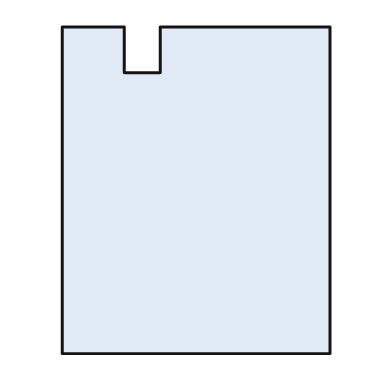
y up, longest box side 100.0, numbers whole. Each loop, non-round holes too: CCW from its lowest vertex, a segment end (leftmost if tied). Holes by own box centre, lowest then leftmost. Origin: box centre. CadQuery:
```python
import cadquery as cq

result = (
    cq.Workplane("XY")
    .moveTo(-41.0, -50.0)
    .lineTo(41.0, -50.0)
    .lineTo(41.0, 50.0)
    .lineTo(-11.0, 50.0)
    .lineTo(-11.0, 36.0)
    .lineTo(-22.0, 36.0)
    .lineTo(-22.0, 50.0)
    .lineTo(-41.0, 50.0)
    .close()
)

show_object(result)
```